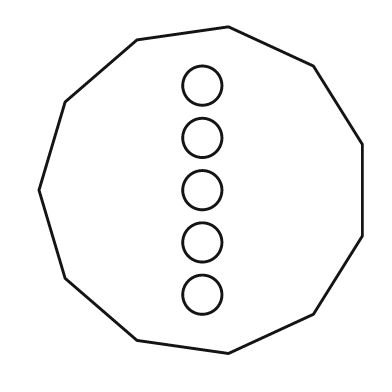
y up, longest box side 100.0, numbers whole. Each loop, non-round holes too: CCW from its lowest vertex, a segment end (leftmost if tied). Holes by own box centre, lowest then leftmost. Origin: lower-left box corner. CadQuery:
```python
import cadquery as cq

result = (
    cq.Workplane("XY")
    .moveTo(58.0, 0.0)
    .lineTo(84.0, 12.0)
    .lineTo(99.0, 36.0)
    .lineTo(99.0, 64.0)
    .lineTo(84.0, 88.0)
    .lineTo(58.0, 100.0)
    .lineTo(30.0, 96.0)
    .lineTo(8.0, 77.0)
    .lineTo(0.0, 50.0)
    .lineTo(8.0, 23.0)
    .lineTo(30.0, 4.0)
    .close()
    .moveTo(50.0, 18.0)
    .circle(6.0)
    .moveTo(50.0, 34.0)
    .circle(6.0)
    .moveTo(50.0, 50.0)
    .circle(6.0)
    .moveTo(50.0, 66.0)
    .circle(6.0)
    .moveTo(50.0, 82.0)
    .circle(6.0)
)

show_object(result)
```